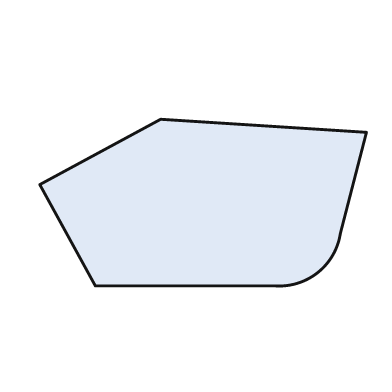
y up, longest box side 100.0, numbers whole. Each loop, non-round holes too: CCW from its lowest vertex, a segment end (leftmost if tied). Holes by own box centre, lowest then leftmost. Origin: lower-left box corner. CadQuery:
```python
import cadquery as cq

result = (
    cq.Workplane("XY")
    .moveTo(17.0, 0.0)
    .lineTo(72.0, 0.0)
    .threePointArc((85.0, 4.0), (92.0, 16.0))
    .lineTo(100.0, 47.0)
    .lineTo(37.0, 51.0)
    .lineTo(0.0, 31.0)
    .close()
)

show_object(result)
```